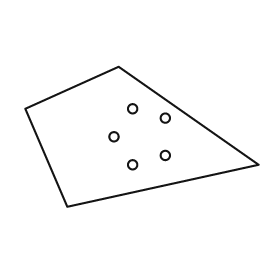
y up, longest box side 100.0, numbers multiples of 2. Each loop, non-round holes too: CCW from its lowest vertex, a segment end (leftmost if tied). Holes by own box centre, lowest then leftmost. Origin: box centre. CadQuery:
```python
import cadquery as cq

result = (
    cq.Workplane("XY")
    .moveTo(-32.0, -30.0)
    .lineTo(50.0, -12.0)
    .lineTo(-10.0, 30.0)
    .lineTo(-50.0, 12.0)
    .close()
    .moveTo(-4.0, -12.0)
    .circle(2.0)
    .moveTo(10.0, -8.0)
    .circle(2.0)
    .moveTo(-12.0, 0.0)
    .circle(2.0)
    .moveTo(10.0, 8.0)
    .circle(2.0)
    .moveTo(-4.0, 12.0)
    .circle(2.0)
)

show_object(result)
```